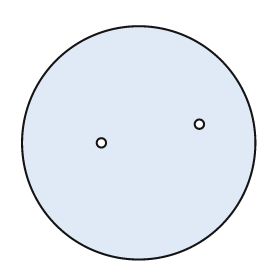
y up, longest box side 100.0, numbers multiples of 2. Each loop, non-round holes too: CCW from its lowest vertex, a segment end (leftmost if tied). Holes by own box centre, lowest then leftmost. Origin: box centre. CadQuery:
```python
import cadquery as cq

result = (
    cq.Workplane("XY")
    .moveTo(0.0, 0.0)
    .circle(50.0)
    .moveTo(-16.0, 0.0)
    .circle(2.0)
    .moveTo(26.0, 8.0)
    .circle(2.0)
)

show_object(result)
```